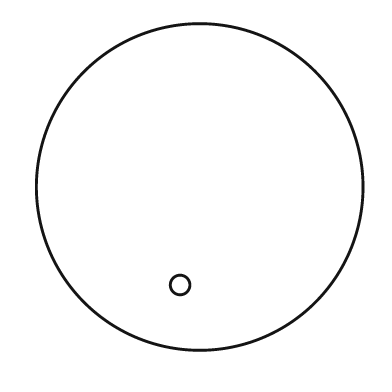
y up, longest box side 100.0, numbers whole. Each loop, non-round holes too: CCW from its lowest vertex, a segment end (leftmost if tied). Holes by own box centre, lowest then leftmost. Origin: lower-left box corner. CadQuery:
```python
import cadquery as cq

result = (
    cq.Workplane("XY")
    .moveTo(50.0, 50.0)
    .circle(50.0)
    .moveTo(44.0, 20.0)
    .circle(3.0)
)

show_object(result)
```